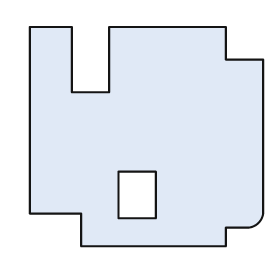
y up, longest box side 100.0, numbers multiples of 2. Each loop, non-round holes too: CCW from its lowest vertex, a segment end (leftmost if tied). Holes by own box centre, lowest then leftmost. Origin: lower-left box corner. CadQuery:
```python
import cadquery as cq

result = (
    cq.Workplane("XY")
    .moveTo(22.0, 0.0)
    .lineTo(84.0, 0.0)
    .lineTo(84.0, 8.0)
    .lineTo(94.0, 8.0)
    .threePointArc((98.0, 10.0), (100.0, 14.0))
    .lineTo(100.0, 80.0)
    .lineTo(84.0, 80.0)
    .lineTo(84.0, 94.0)
    .lineTo(34.0, 94.0)
    .lineTo(34.0, 66.0)
    .lineTo(18.0, 66.0)
    .lineTo(18.0, 94.0)
    .lineTo(0.0, 94.0)
    .lineTo(0.0, 14.0)
    .lineTo(22.0, 14.0)
    .close()
    .moveTo(38.0, 12.0)
    .lineTo(54.0, 12.0)
    .lineTo(54.0, 32.0)
    .lineTo(38.0, 32.0)
    .close()
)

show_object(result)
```